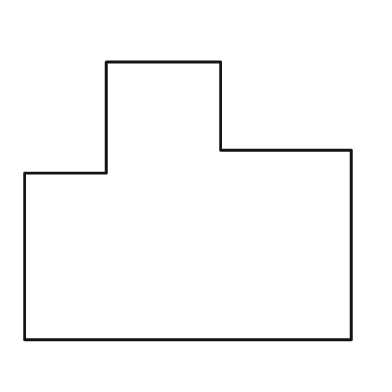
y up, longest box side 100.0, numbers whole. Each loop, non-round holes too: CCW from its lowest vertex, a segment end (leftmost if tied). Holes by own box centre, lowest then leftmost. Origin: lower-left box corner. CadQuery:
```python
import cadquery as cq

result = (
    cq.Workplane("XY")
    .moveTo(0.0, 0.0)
    .lineTo(100.0, 0.0)
    .lineTo(100.0, 58.0)
    .lineTo(60.0, 58.0)
    .lineTo(60.0, 85.0)
    .lineTo(25.0, 85.0)
    .lineTo(25.0, 51.0)
    .lineTo(0.0, 51.0)
    .close()
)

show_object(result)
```